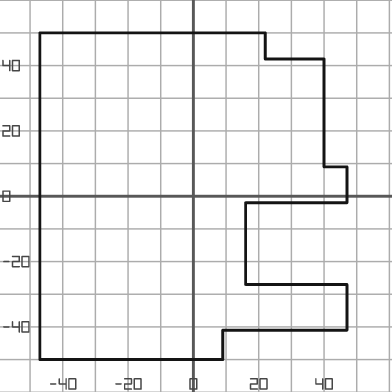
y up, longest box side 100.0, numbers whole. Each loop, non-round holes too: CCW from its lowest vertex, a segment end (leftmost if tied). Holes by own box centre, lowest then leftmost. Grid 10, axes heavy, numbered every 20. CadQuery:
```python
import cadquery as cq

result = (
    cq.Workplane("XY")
    .moveTo(-47.0, -50.0)
    .lineTo(9.0, -50.0)
    .lineTo(9.0, -41.0)
    .lineTo(47.0, -41.0)
    .lineTo(47.0, -27.0)
    .lineTo(16.0, -27.0)
    .lineTo(16.0, -2.0)
    .lineTo(47.0, -2.0)
    .lineTo(47.0, 9.0)
    .lineTo(40.0, 9.0)
    .lineTo(40.0, 42.0)
    .lineTo(22.0, 42.0)
    .lineTo(22.0, 50.0)
    .lineTo(-47.0, 50.0)
    .close()
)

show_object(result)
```